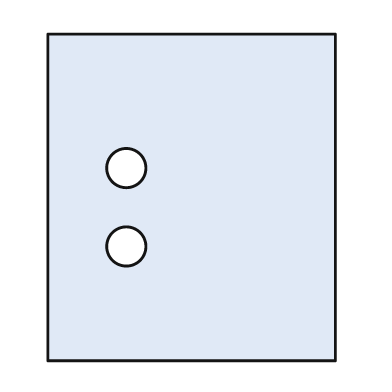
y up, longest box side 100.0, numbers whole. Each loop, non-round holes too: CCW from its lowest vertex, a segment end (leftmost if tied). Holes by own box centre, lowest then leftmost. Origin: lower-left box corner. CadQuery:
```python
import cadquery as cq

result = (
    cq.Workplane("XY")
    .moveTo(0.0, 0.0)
    .lineTo(88.0, 0.0)
    .lineTo(88.0, 100.0)
    .lineTo(0.0, 100.0)
    .close()
    .moveTo(24.0, 35.0)
    .circle(6.0)
    .moveTo(24.0, 59.0)
    .circle(6.0)
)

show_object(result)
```